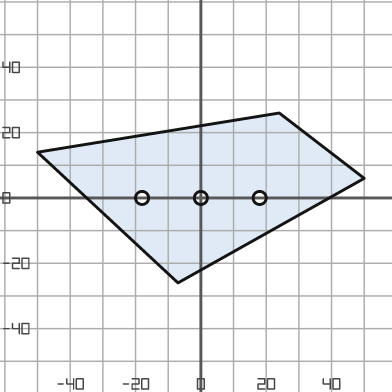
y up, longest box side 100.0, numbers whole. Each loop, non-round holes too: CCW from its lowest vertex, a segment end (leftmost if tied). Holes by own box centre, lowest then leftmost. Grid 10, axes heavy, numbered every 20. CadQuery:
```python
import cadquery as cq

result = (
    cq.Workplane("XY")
    .moveTo(-7.0, -26.0)
    .lineTo(50.0, 6.0)
    .lineTo(24.0, 26.0)
    .lineTo(-50.0, 14.0)
    .close()
    .moveTo(-18.0, 0.0)
    .circle(2.0)
    .moveTo(0.0, 0.0)
    .circle(2.0)
    .moveTo(18.0, 0.0)
    .circle(2.0)
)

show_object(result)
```